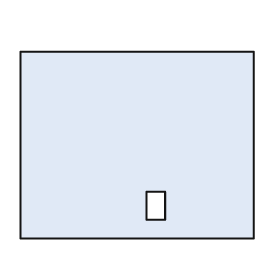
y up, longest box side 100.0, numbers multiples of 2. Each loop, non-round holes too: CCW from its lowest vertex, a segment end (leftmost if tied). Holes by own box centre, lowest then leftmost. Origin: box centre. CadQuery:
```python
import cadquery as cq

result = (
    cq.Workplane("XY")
    .moveTo(-50.0, -40.0)
    .lineTo(50.0, -40.0)
    .lineTo(50.0, 40.0)
    .lineTo(-50.0, 40.0)
    .close()
    .moveTo(4.0, -32.0)
    .lineTo(12.0, -32.0)
    .lineTo(12.0, -20.0)
    .lineTo(4.0, -20.0)
    .close()
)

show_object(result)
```